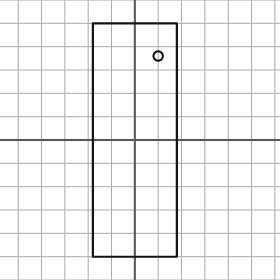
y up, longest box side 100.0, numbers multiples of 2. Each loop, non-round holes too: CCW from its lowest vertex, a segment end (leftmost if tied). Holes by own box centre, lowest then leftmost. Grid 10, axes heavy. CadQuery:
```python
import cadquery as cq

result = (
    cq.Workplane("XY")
    .moveTo(-18.0, -50.0)
    .lineTo(18.0, -50.0)
    .lineTo(18.0, 50.0)
    .lineTo(-18.0, 50.0)
    .close()
    .moveTo(10.0, 36.0)
    .circle(2.0)
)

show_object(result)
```